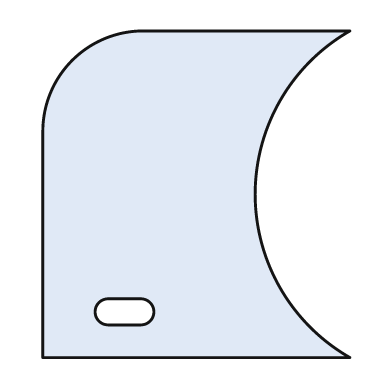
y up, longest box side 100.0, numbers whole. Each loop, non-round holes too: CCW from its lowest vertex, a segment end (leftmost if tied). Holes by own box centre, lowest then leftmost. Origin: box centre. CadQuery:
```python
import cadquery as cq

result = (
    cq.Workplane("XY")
    .moveTo(-47.0, -50.0)
    .lineTo(47.0, -50.0)
    .threePointArc((18.0, 0.0), (47.0, 50.0))
    .lineTo(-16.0, 50.0)
    .threePointArc((-38.0, 41.0), (-47.0, 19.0))
    .close()
    .moveTo(-27.0, -40.0)
    .lineTo(-17.0, -40.0)
    .threePointArc((-13.0, -36.0), (-17.0, -32.0))
    .lineTo(-27.0, -32.0)
    .threePointArc((-31.0, -36.0), (-27.0, -40.0))
    .close()
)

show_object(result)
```